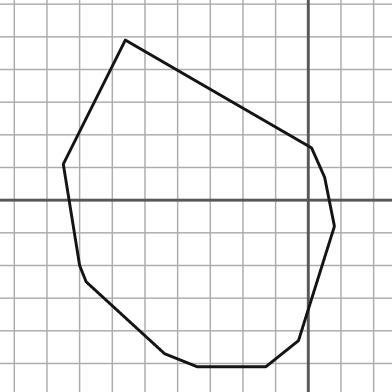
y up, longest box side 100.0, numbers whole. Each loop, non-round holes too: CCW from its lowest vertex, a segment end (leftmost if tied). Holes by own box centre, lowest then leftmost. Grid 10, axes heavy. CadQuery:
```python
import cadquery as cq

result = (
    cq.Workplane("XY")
    .moveTo(-34.0, -51.0)
    .lineTo(-13.0, -51.0)
    .lineTo(-3.0, -43.0)
    .lineTo(8.0, -8.0)
    .lineTo(5.0, 7.0)
    .lineTo(1.0, 16.0)
    .lineTo(-56.0, 49.0)
    .lineTo(-75.0, 11.0)
    .lineTo(-70.0, -20.0)
    .lineTo(-68.0, -25.0)
    .lineTo(-44.0, -47.0)
    .close()
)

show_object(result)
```